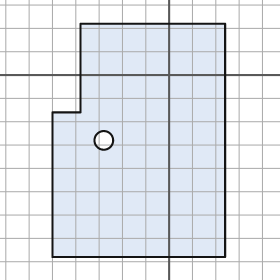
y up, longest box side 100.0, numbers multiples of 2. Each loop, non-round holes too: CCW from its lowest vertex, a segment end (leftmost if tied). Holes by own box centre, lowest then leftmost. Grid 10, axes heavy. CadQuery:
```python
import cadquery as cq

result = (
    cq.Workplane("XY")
    .moveTo(-50.0, -78.0)
    .lineTo(24.0, -78.0)
    .lineTo(24.0, 22.0)
    .lineTo(-38.0, 22.0)
    .lineTo(-38.0, -16.0)
    .lineTo(-50.0, -16.0)
    .close()
    .moveTo(-28.0, -28.0)
    .circle(4.0)
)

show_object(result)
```